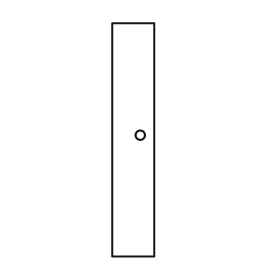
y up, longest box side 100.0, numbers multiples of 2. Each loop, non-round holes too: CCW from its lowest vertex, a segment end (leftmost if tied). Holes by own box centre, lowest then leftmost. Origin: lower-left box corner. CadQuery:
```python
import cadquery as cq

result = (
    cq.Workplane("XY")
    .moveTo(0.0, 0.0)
    .lineTo(18.0, 0.0)
    .lineTo(18.0, 100.0)
    .lineTo(0.0, 100.0)
    .close()
    .moveTo(12.0, 52.0)
    .circle(2.0)
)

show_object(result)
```